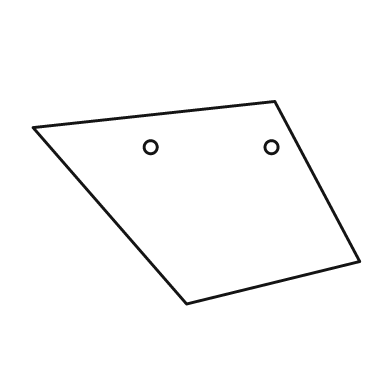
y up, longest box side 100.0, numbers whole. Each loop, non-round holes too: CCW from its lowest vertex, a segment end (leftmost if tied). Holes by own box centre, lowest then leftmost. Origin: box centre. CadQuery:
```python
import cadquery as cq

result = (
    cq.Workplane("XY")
    .moveTo(-3.0, -31.0)
    .lineTo(50.0, -18.0)
    .lineTo(24.0, 31.0)
    .lineTo(-50.0, 23.0)
    .close()
    .moveTo(-14.0, 17.0)
    .circle(2.0)
    .moveTo(23.0, 17.0)
    .circle(2.0)
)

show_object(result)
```